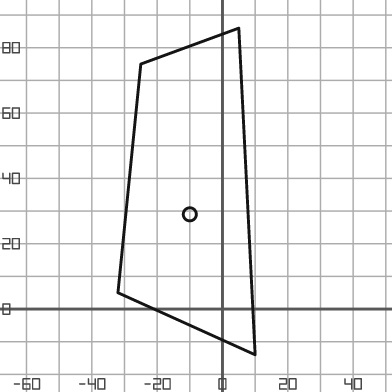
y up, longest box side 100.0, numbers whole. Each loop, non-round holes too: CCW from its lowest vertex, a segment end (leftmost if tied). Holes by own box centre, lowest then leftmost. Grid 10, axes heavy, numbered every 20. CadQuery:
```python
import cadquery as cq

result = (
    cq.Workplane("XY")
    .moveTo(10.0, -14.0)
    .lineTo(5.0, 86.0)
    .lineTo(-25.0, 75.0)
    .lineTo(-32.0, 5.0)
    .close()
    .moveTo(-10.0, 29.0)
    .circle(2.0)
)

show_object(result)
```